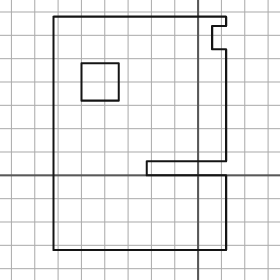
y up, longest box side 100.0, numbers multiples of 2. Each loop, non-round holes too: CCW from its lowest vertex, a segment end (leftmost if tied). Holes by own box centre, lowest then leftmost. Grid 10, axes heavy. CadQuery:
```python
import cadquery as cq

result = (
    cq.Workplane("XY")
    .moveTo(-62.0, -32.0)
    .lineTo(12.0, -32.0)
    .lineTo(12.0, 0.0)
    .lineTo(-22.0, 0.0)
    .lineTo(-22.0, 6.0)
    .lineTo(12.0, 6.0)
    .lineTo(12.0, 54.0)
    .lineTo(6.0, 54.0)
    .lineTo(6.0, 64.0)
    .lineTo(12.0, 64.0)
    .lineTo(12.0, 68.0)
    .lineTo(-62.0, 68.0)
    .close()
    .moveTo(-50.0, 32.0)
    .lineTo(-34.0, 32.0)
    .lineTo(-34.0, 48.0)
    .lineTo(-50.0, 48.0)
    .close()
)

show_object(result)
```